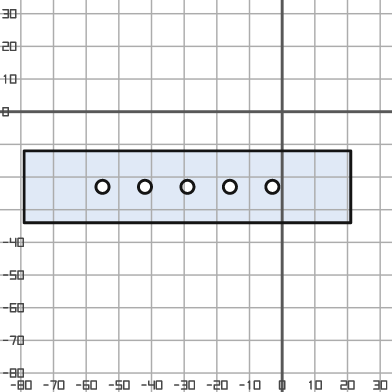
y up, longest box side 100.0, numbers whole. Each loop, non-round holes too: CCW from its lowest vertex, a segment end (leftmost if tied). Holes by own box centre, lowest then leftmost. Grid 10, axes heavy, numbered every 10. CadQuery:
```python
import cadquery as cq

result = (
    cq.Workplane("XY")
    .moveTo(-79.0, -34.0)
    .lineTo(21.0, -34.0)
    .lineTo(21.0, -12.0)
    .lineTo(-79.0, -12.0)
    .close()
    .moveTo(-55.0, -23.0)
    .circle(2.0)
    .moveTo(-42.0, -23.0)
    .circle(2.0)
    .moveTo(-29.0, -23.0)
    .circle(2.0)
    .moveTo(-16.0, -23.0)
    .circle(2.0)
    .moveTo(-3.0, -23.0)
    .circle(2.0)
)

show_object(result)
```